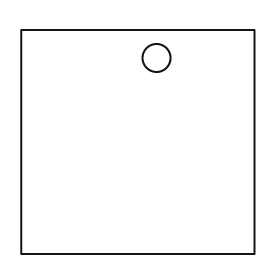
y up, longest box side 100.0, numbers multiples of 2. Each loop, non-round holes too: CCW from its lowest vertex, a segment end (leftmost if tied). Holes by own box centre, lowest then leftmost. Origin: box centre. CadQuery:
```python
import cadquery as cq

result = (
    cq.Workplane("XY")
    .moveTo(-50.0, -48.0)
    .lineTo(50.0, -48.0)
    .lineTo(50.0, 48.0)
    .lineTo(-50.0, 48.0)
    .close()
    .moveTo(8.0, 36.0)
    .circle(6.0)
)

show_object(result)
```